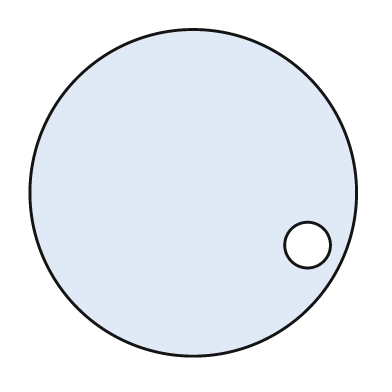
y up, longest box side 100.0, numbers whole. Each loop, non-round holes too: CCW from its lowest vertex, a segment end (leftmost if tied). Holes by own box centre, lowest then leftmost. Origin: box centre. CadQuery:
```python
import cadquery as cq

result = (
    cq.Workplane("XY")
    .moveTo(0.0, 0.0)
    .circle(50.0)
    .moveTo(35.0, -16.0)
    .circle(7.0)
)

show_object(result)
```